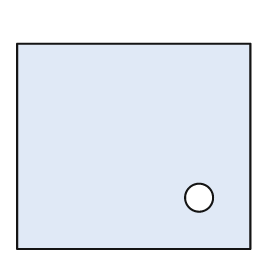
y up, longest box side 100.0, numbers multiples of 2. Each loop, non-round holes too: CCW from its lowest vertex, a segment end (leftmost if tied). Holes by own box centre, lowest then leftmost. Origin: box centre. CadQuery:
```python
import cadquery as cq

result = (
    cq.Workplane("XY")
    .moveTo(-50.0, -44.0)
    .lineTo(50.0, -44.0)
    .lineTo(50.0, 44.0)
    .lineTo(-50.0, 44.0)
    .close()
    .moveTo(28.0, -22.0)
    .circle(6.0)
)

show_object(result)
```